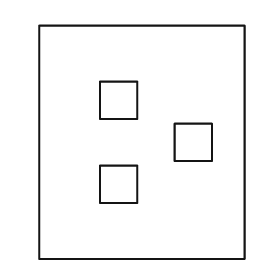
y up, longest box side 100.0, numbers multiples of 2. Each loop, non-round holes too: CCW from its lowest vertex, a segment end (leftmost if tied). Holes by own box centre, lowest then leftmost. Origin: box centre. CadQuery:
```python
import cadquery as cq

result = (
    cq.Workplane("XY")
    .moveTo(-44.0, -50.0)
    .lineTo(44.0, -50.0)
    .lineTo(44.0, 50.0)
    .lineTo(-44.0, 50.0)
    .close()
    .moveTo(-18.0, -26.0)
    .lineTo(-2.0, -26.0)
    .lineTo(-2.0, -10.0)
    .lineTo(-18.0, -10.0)
    .close()
    .moveTo(14.0, -8.0)
    .lineTo(30.0, -8.0)
    .lineTo(30.0, 8.0)
    .lineTo(14.0, 8.0)
    .close()
    .moveTo(-18.0, 10.0)
    .lineTo(-2.0, 10.0)
    .lineTo(-2.0, 26.0)
    .lineTo(-18.0, 26.0)
    .close()
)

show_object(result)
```